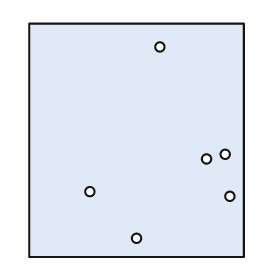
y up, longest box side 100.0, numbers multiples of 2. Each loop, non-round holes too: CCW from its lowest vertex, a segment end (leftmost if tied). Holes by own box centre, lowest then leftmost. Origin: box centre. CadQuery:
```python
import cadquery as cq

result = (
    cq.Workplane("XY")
    .moveTo(-46.0, -50.0)
    .lineTo(46.0, -50.0)
    .lineTo(46.0, 50.0)
    .lineTo(-46.0, 50.0)
    .close()
    .moveTo(0.0, -42.0)
    .circle(2.0)
    .moveTo(40.0, -24.0)
    .circle(2.0)
    .moveTo(-20.0, -22.0)
    .circle(2.0)
    .moveTo(30.0, -8.0)
    .circle(2.0)
    .moveTo(38.0, -6.0)
    .circle(2.0)
    .moveTo(10.0, 40.0)
    .circle(2.0)
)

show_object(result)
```